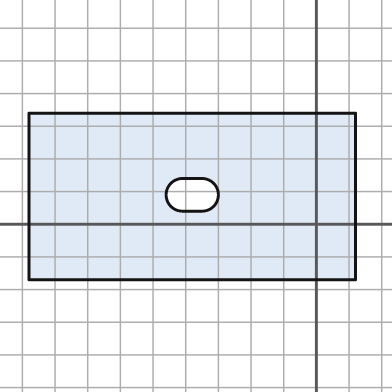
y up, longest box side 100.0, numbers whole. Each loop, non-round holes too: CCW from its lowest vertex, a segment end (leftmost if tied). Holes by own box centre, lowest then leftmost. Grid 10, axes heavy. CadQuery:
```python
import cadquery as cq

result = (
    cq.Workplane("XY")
    .moveTo(-88.0, -17.0)
    .lineTo(12.0, -17.0)
    .lineTo(12.0, 34.0)
    .lineTo(-88.0, 34.0)
    .close()
    .moveTo(-41.0, 4.0)
    .lineTo(-35.0, 4.0)
    .threePointArc((-30.0, 9.0), (-35.0, 14.0))
    .lineTo(-41.0, 14.0)
    .threePointArc((-46.0, 9.0), (-41.0, 4.0))
    .close()
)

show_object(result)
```